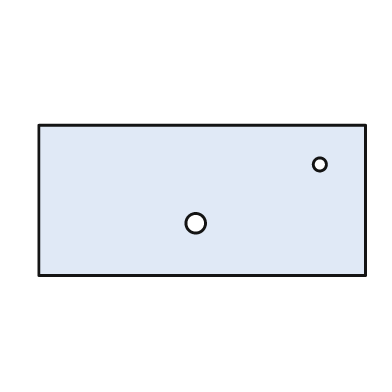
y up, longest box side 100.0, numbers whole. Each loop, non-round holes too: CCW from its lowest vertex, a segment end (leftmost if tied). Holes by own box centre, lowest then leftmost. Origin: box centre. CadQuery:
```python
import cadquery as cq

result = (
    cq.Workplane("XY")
    .moveTo(-50.0, -23.0)
    .lineTo(50.0, -23.0)
    .lineTo(50.0, 23.0)
    .lineTo(-50.0, 23.0)
    .close()
    .moveTo(-2.0, -7.0)
    .circle(3.0)
    .moveTo(36.0, 11.0)
    .circle(2.0)
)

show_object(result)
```